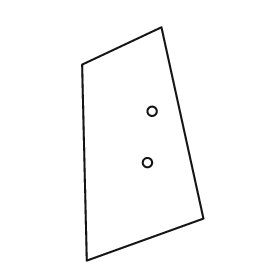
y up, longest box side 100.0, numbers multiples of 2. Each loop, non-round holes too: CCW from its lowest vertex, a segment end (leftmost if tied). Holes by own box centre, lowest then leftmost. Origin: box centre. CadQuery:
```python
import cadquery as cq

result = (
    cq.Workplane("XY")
    .moveTo(-24.0, -50.0)
    .lineTo(26.0, -32.0)
    .lineTo(8.0, 50.0)
    .lineTo(-26.0, 34.0)
    .close()
    .moveTo(2.0, -8.0)
    .circle(2.0)
    .moveTo(4.0, 14.0)
    .circle(2.0)
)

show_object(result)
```